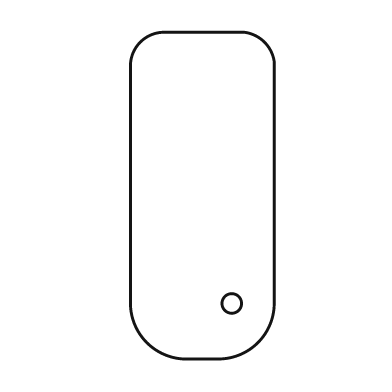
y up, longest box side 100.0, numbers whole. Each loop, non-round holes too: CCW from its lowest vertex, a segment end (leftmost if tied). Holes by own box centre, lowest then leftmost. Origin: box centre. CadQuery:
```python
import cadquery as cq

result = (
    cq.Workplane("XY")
    .moveTo(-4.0, -50.0)
    .lineTo(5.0, -50.0)
    .threePointArc((17.0, -45.0), (22.0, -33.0))
    .lineTo(22.0, 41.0)
    .threePointArc((19.0, 47.0), (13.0, 50.0))
    .lineTo(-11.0, 50.0)
    .threePointArc((-19.0, 47.0), (-22.0, 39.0))
    .lineTo(-22.0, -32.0)
    .threePointArc((-17.0, -45.0), (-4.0, -50.0))
    .close()
    .moveTo(9.0, -33.0)
    .circle(3.0)
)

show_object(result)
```